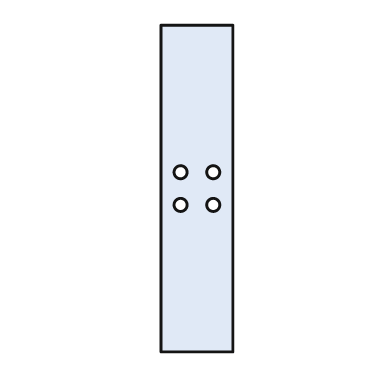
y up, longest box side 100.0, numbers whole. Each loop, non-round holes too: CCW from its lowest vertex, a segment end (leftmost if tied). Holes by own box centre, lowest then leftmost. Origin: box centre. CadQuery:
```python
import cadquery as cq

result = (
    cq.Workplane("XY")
    .moveTo(-11.0, -50.0)
    .lineTo(11.0, -50.0)
    .lineTo(11.0, 50.0)
    .lineTo(-11.0, 50.0)
    .close()
    .moveTo(-5.0, -5.0)
    .circle(2.0)
    .moveTo(5.0, -5.0)
    .circle(2.0)
    .moveTo(-5.0, 5.0)
    .circle(2.0)
    .moveTo(5.0, 5.0)
    .circle(2.0)
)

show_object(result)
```